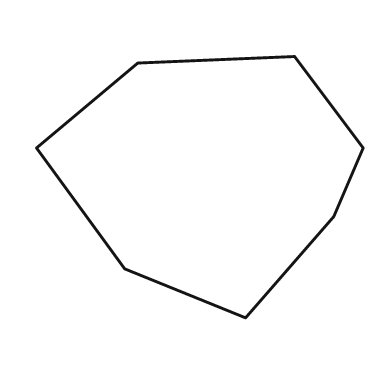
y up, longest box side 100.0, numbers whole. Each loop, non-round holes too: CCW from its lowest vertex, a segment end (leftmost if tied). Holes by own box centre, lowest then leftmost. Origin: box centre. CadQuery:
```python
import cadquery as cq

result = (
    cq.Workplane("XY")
    .moveTo(14.0, -40.0)
    .lineTo(41.0, -9.0)
    .lineTo(50.0, 12.0)
    .lineTo(29.0, 40.0)
    .lineTo(-19.0, 38.0)
    .lineTo(-50.0, 12.0)
    .lineTo(-23.0, -25.0)
    .close()
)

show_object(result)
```